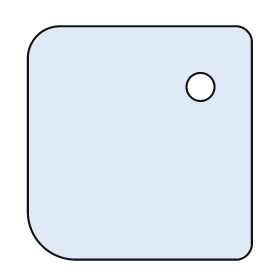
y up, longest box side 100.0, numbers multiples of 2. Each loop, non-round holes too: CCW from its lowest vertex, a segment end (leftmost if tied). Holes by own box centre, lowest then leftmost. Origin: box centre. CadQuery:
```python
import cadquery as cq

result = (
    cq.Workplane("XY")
    .moveTo(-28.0, -50.0)
    .lineTo(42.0, -50.0)
    .threePointArc((46.0, -48.0), (48.0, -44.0))
    .lineTo(48.0, 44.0)
    .threePointArc((46.0, 48.0), (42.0, 50.0))
    .lineTo(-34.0, 50.0)
    .threePointArc((-44.0, 46.0), (-48.0, 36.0))
    .lineTo(-48.0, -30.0)
    .threePointArc((-42.0, -44.0), (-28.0, -50.0))
    .close()
    .moveTo(26.0, 24.0)
    .circle(6.0)
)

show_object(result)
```